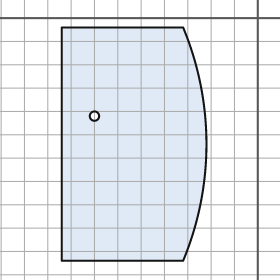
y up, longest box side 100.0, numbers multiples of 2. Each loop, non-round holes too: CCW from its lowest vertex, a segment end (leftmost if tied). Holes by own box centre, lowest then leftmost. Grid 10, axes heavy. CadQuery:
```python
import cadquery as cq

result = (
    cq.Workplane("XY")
    .moveTo(-84.0, -104.0)
    .lineTo(-32.0, -104.0)
    .threePointArc((-22.0, -54.0), (-32.0, -4.0))
    .lineTo(-84.0, -4.0)
    .close()
    .moveTo(-70.0, -42.0)
    .circle(2.0)
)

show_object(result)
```